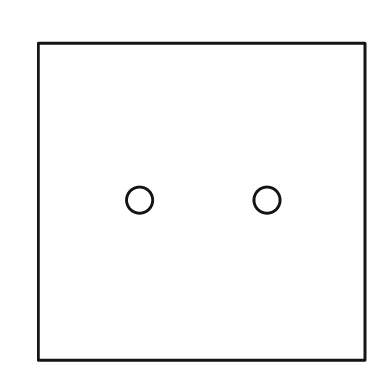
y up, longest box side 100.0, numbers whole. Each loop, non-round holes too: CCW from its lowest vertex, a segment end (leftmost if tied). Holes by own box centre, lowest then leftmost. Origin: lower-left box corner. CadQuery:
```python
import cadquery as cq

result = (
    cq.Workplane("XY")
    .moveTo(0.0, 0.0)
    .lineTo(100.0, 0.0)
    .lineTo(100.0, 97.0)
    .lineTo(0.0, 97.0)
    .close()
    .moveTo(31.0, 49.0)
    .circle(4.0)
    .moveTo(70.0, 49.0)
    .circle(4.0)
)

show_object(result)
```